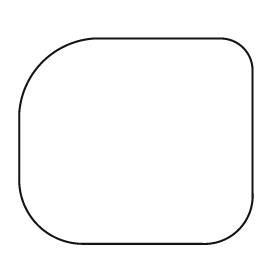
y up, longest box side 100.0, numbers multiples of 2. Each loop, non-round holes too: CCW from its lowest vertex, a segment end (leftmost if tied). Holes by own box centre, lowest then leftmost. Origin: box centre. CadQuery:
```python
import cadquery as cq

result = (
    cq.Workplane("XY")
    .moveTo(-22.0, -44.0)
    .lineTo(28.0, -44.0)
    .threePointArc((44.0, -38.0), (50.0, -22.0))
    .lineTo(50.0, 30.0)
    .threePointArc((46.0, 40.0), (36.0, 44.0))
    .lineTo(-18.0, 44.0)
    .threePointArc((-40.0, 34.0), (-50.0, 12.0))
    .lineTo(-50.0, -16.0)
    .threePointArc((-42.0, -36.0), (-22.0, -44.0))
    .close()
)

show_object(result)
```